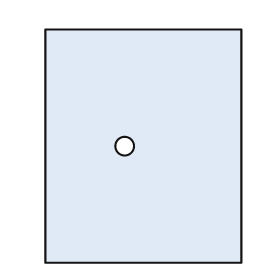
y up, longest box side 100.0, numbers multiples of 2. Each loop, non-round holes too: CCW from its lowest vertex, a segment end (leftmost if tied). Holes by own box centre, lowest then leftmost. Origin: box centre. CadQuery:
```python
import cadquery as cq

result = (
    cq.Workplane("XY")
    .moveTo(-42.0, -50.0)
    .lineTo(42.0, -50.0)
    .lineTo(42.0, 50.0)
    .lineTo(-42.0, 50.0)
    .close()
    .moveTo(-8.0, 0.0)
    .circle(4.0)
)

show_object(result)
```